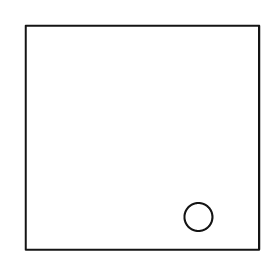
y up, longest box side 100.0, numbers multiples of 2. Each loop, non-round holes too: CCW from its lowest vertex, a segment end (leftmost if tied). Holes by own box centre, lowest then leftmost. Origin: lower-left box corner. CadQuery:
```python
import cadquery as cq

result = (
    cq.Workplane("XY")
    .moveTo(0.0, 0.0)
    .lineTo(100.0, 0.0)
    .lineTo(100.0, 96.0)
    .lineTo(0.0, 96.0)
    .close()
    .moveTo(74.0, 14.0)
    .circle(6.0)
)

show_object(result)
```